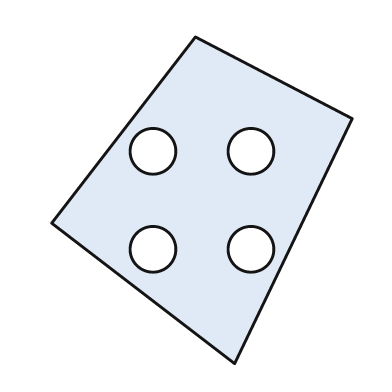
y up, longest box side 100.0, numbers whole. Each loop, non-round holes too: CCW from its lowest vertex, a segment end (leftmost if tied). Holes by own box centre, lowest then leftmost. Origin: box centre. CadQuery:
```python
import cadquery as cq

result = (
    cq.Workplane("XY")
    .moveTo(10.0, -50.0)
    .lineTo(46.0, 25.0)
    .lineTo(-2.0, 50.0)
    .lineTo(-46.0, -7.0)
    .close()
    .moveTo(-15.0, -15.0)
    .circle(7.0)
    .moveTo(15.0, -15.0)
    .circle(7.0)
    .moveTo(-15.0, 15.0)
    .circle(7.0)
    .moveTo(15.0, 15.0)
    .circle(7.0)
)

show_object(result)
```